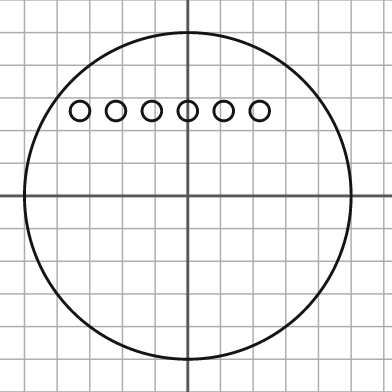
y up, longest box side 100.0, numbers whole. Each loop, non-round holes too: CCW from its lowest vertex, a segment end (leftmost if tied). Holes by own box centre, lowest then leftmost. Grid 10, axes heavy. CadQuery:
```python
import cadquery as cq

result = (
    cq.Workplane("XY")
    .moveTo(0.0, 0.0)
    .circle(50.0)
    .moveTo(-33.0, 26.0)
    .circle(3.0)
    .moveTo(-22.0, 26.0)
    .circle(3.0)
    .moveTo(-11.0, 26.0)
    .circle(3.0)
    .moveTo(0.0, 26.0)
    .circle(3.0)
    .moveTo(11.0, 26.0)
    .circle(3.0)
    .moveTo(22.0, 26.0)
    .circle(3.0)
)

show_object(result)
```